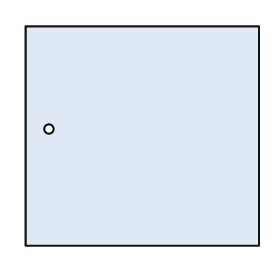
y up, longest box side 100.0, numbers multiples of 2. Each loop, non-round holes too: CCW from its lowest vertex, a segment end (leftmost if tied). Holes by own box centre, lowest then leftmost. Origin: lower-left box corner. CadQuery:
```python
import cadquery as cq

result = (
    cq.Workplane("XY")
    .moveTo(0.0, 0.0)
    .lineTo(100.0, 0.0)
    .lineTo(100.0, 94.0)
    .lineTo(0.0, 94.0)
    .close()
    .moveTo(10.0, 50.0)
    .circle(2.0)
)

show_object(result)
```